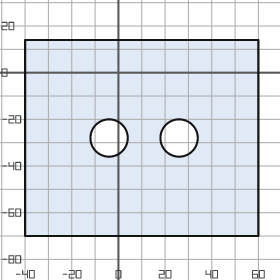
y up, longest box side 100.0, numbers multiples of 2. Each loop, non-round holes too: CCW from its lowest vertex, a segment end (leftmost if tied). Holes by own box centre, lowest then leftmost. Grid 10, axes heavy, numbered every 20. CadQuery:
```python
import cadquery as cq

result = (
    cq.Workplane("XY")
    .moveTo(-40.0, -70.0)
    .lineTo(60.0, -70.0)
    .lineTo(60.0, 14.0)
    .lineTo(-40.0, 14.0)
    .close()
    .moveTo(-4.0, -28.0)
    .circle(8.0)
    .moveTo(26.0, -28.0)
    .circle(8.0)
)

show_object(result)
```